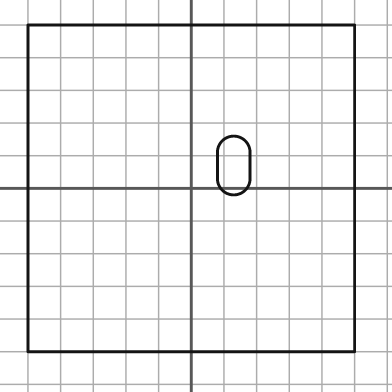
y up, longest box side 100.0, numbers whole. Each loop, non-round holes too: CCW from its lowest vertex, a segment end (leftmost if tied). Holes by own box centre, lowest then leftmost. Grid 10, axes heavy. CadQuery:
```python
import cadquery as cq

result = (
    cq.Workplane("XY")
    .moveTo(-50.0, -50.0)
    .lineTo(50.0, -50.0)
    .lineTo(50.0, 50.0)
    .lineTo(-50.0, 50.0)
    .close()
    .moveTo(8.0, 3.0)
    .threePointArc((13.0, -2.0), (18.0, 3.0))
    .lineTo(18.0, 11.0)
    .threePointArc((13.0, 16.0), (8.0, 11.0))
    .close()
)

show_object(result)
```